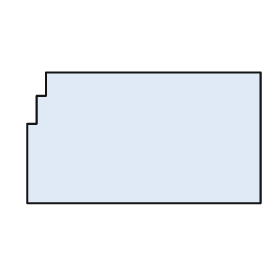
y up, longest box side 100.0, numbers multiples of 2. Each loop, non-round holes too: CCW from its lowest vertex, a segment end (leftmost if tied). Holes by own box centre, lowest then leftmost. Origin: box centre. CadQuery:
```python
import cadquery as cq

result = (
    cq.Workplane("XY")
    .moveTo(-50.0, -28.0)
    .lineTo(50.0, -28.0)
    .lineTo(50.0, 28.0)
    .lineTo(-42.0, 28.0)
    .lineTo(-42.0, 18.0)
    .lineTo(-46.0, 18.0)
    .lineTo(-46.0, 6.0)
    .lineTo(-50.0, 6.0)
    .close()
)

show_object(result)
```